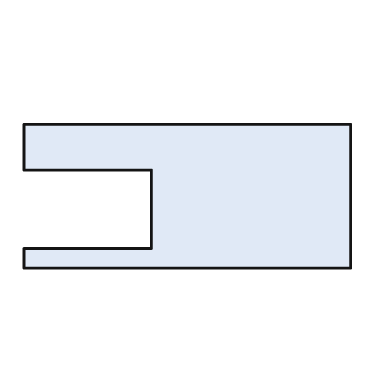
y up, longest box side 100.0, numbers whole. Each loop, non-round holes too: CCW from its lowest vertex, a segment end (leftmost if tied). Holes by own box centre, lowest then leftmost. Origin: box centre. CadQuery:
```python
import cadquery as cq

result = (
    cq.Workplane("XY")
    .moveTo(-50.0, -22.0)
    .lineTo(50.0, -22.0)
    .lineTo(50.0, 22.0)
    .lineTo(-50.0, 22.0)
    .lineTo(-50.0, 8.0)
    .lineTo(-11.0, 8.0)
    .lineTo(-11.0, -16.0)
    .lineTo(-50.0, -16.0)
    .close()
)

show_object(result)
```